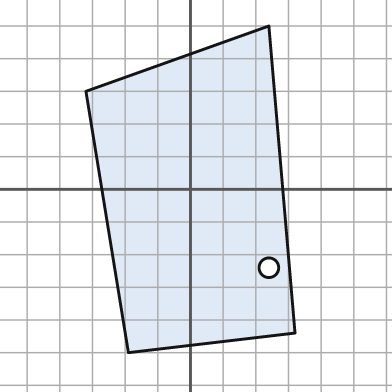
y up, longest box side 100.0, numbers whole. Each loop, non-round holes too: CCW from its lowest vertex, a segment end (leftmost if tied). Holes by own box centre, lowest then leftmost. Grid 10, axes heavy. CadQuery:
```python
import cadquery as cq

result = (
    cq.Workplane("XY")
    .moveTo(-19.0, -50.0)
    .lineTo(32.0, -44.0)
    .lineTo(24.0, 50.0)
    .lineTo(-32.0, 30.0)
    .close()
    .moveTo(24.0, -24.0)
    .circle(3.0)
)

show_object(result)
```